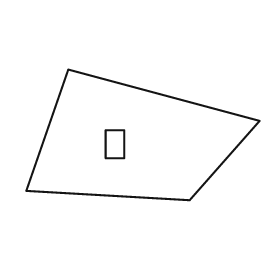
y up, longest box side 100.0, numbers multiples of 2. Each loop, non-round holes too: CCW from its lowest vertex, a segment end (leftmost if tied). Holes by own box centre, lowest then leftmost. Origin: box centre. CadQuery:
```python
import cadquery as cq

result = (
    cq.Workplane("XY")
    .moveTo(20.0, -28.0)
    .lineTo(50.0, 6.0)
    .lineTo(-32.0, 28.0)
    .lineTo(-50.0, -24.0)
    .close()
    .moveTo(-16.0, -10.0)
    .lineTo(-8.0, -10.0)
    .lineTo(-8.0, 2.0)
    .lineTo(-16.0, 2.0)
    .close()
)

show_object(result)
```